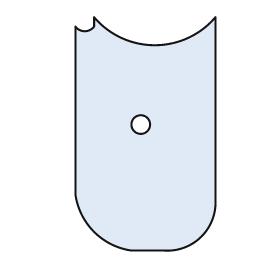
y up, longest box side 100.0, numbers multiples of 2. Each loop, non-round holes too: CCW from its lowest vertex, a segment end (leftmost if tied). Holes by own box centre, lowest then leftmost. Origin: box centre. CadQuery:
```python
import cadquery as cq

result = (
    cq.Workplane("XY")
    .moveTo(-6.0, -50.0)
    .lineTo(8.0, -50.0)
    .threePointArc((24.0, -44.0), (30.0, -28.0))
    .lineTo(30.0, 50.0)
    .threePointArc((4.0, 38.0), (-22.0, 50.0))
    .lineTo(-22.0, 46.0)
    .threePointArc((-26.0, 44.0), (-30.0, 46.0))
    .lineTo(-30.0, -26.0)
    .threePointArc((-22.0, -42.0), (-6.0, -50.0))
    .close()
    .moveTo(-2.0, 4.0)
    .circle(4.0)
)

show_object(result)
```